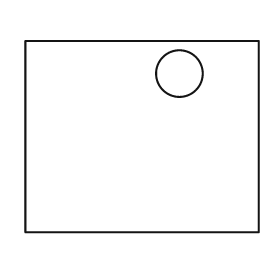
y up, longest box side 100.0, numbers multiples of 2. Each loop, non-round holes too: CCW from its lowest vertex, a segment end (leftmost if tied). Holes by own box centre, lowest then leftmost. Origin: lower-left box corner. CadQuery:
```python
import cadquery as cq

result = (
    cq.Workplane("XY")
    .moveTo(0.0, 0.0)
    .lineTo(100.0, 0.0)
    .lineTo(100.0, 82.0)
    .lineTo(0.0, 82.0)
    .close()
    .moveTo(66.0, 68.0)
    .circle(10.0)
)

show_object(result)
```